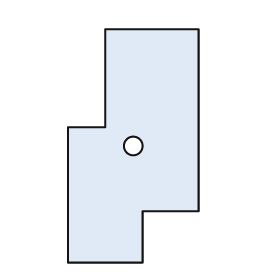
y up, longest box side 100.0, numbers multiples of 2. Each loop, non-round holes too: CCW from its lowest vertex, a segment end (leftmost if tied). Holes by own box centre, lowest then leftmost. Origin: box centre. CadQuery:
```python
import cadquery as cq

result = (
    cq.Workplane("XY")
    .moveTo(-28.0, -50.0)
    .lineTo(4.0, -50.0)
    .lineTo(4.0, -28.0)
    .lineTo(28.0, -28.0)
    .lineTo(28.0, 50.0)
    .lineTo(-12.0, 50.0)
    .lineTo(-12.0, 8.0)
    .lineTo(-28.0, 8.0)
    .close()
    .moveTo(0.0, 0.0)
    .circle(4.0)
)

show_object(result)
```